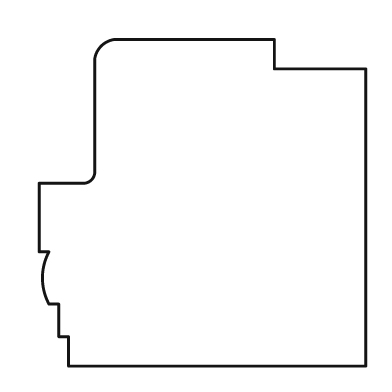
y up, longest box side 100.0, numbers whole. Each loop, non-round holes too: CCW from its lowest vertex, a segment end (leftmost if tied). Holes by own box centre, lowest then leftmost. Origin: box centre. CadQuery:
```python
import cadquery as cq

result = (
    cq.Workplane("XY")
    .moveTo(-41.0, -50.0)
    .lineTo(50.0, -50.0)
    .lineTo(50.0, 41.0)
    .lineTo(22.0, 41.0)
    .lineTo(22.0, 50.0)
    .lineTo(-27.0, 50.0)
    .threePointArc((-31.0, 48.0), (-33.0, 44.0))
    .lineTo(-33.0, 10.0)
    .threePointArc((-34.0, 7.0), (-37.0, 6.0))
    .lineTo(-50.0, 6.0)
    .lineTo(-50.0, -15.0)
    .lineTo(-47.0, -15.0)
    .threePointArc((-49.0, -23.0), (-47.0, -31.0))
    .lineTo(-44.0, -31.0)
    .lineTo(-44.0, -41.0)
    .lineTo(-41.0, -41.0)
    .close()
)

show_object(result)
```